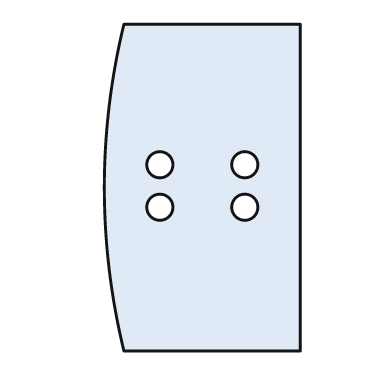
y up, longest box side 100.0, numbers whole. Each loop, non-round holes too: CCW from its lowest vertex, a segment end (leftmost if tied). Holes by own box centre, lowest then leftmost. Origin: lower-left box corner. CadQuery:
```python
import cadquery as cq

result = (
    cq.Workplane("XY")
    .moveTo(6.0, 0.0)
    .lineTo(60.0, 0.0)
    .lineTo(60.0, 100.0)
    .lineTo(6.0, 100.0)
    .threePointArc((0.0, 50.0), (6.0, 0.0))
    .close()
    .moveTo(17.0, 44.0)
    .circle(4.0)
    .moveTo(43.0, 44.0)
    .circle(4.0)
    .moveTo(17.0, 57.0)
    .circle(4.0)
    .moveTo(43.0, 57.0)
    .circle(4.0)
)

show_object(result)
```